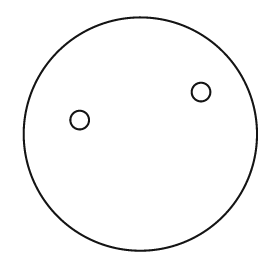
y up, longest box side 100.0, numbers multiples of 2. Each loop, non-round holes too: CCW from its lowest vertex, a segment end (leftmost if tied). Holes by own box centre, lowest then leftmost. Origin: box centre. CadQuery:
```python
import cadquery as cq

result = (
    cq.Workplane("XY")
    .moveTo(0.0, 0.0)
    .circle(50.0)
    .moveTo(-26.0, 6.0)
    .circle(4.0)
    .moveTo(26.0, 18.0)
    .circle(4.0)
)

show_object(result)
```